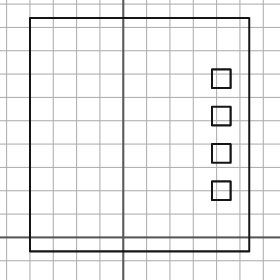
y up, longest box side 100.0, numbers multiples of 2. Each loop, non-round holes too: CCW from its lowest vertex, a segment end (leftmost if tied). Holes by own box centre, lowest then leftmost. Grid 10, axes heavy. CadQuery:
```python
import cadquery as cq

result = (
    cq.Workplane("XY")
    .moveTo(-40.0, -6.0)
    .lineTo(54.0, -6.0)
    .lineTo(54.0, 94.0)
    .lineTo(-40.0, 94.0)
    .close()
    .moveTo(38.0, 16.0)
    .lineTo(46.0, 16.0)
    .lineTo(46.0, 24.0)
    .lineTo(38.0, 24.0)
    .close()
    .moveTo(38.0, 32.0)
    .lineTo(46.0, 32.0)
    .lineTo(46.0, 40.0)
    .lineTo(38.0, 40.0)
    .close()
    .moveTo(38.0, 48.0)
    .lineTo(46.0, 48.0)
    .lineTo(46.0, 56.0)
    .lineTo(38.0, 56.0)
    .close()
    .moveTo(38.0, 64.0)
    .lineTo(46.0, 64.0)
    .lineTo(46.0, 72.0)
    .lineTo(38.0, 72.0)
    .close()
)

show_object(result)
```